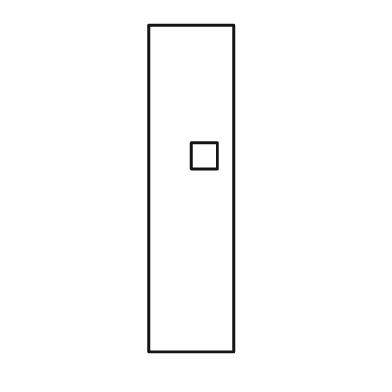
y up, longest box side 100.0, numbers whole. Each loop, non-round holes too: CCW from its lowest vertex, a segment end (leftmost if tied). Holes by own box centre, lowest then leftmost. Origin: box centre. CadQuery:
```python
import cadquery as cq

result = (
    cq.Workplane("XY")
    .moveTo(-13.0, -50.0)
    .lineTo(13.0, -50.0)
    .lineTo(13.0, 50.0)
    .lineTo(-13.0, 50.0)
    .close()
    .moveTo(0.0, 6.0)
    .lineTo(8.0, 6.0)
    .lineTo(8.0, 14.0)
    .lineTo(0.0, 14.0)
    .close()
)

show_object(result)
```